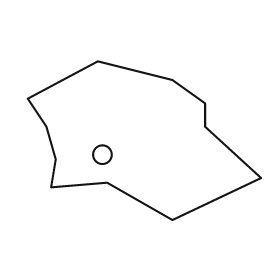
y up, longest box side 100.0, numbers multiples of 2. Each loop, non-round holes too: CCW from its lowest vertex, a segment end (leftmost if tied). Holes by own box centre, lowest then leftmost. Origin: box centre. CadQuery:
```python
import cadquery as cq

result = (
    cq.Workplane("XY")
    .moveTo(12.0, -34.0)
    .lineTo(50.0, -16.0)
    .lineTo(26.0, 6.0)
    .lineTo(26.0, 16.0)
    .lineTo(12.0, 26.0)
    .lineTo(-20.0, 34.0)
    .lineTo(-50.0, 18.0)
    .lineTo(-42.0, 6.0)
    .lineTo(-38.0, -8.0)
    .lineTo(-40.0, -20.0)
    .lineTo(-16.0, -18.0)
    .close()
    .moveTo(-18.0, -6.0)
    .circle(4.0)
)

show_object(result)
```